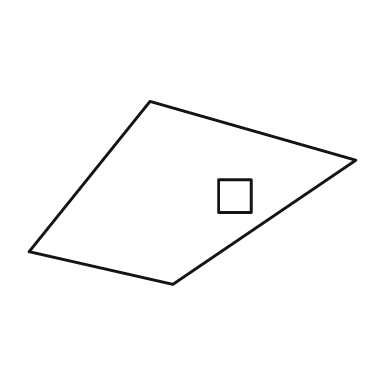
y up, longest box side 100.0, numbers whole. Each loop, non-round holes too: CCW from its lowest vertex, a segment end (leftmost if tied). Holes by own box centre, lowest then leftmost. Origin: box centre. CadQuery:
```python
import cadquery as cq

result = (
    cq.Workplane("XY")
    .moveTo(-6.0, -28.0)
    .lineTo(50.0, 10.0)
    .lineTo(-13.0, 28.0)
    .lineTo(-50.0, -18.0)
    .close()
    .moveTo(8.0, -6.0)
    .lineTo(18.0, -6.0)
    .lineTo(18.0, 4.0)
    .lineTo(8.0, 4.0)
    .close()
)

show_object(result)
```